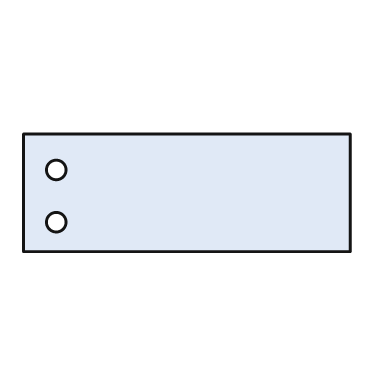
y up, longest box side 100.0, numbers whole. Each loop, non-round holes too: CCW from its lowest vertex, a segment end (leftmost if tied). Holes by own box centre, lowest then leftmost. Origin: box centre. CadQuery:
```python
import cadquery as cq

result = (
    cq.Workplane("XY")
    .moveTo(-50.0, -18.0)
    .lineTo(50.0, -18.0)
    .lineTo(50.0, 18.0)
    .lineTo(-50.0, 18.0)
    .close()
    .moveTo(-40.0, -9.0)
    .circle(3.0)
    .moveTo(-40.0, 7.0)
    .circle(3.0)
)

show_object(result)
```